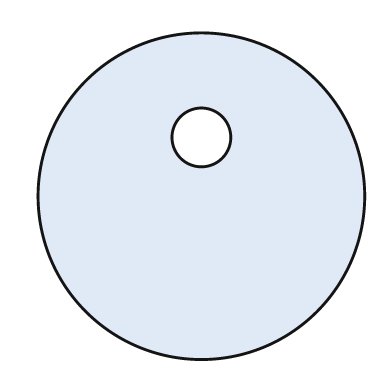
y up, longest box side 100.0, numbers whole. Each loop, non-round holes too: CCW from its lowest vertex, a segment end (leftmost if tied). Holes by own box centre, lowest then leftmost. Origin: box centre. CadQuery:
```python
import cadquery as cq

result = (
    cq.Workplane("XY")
    .moveTo(0.0, 0.0)
    .circle(50.0)
    .moveTo(0.0, 18.0)
    .circle(9.0)
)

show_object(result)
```